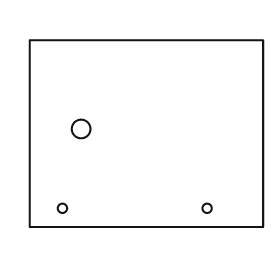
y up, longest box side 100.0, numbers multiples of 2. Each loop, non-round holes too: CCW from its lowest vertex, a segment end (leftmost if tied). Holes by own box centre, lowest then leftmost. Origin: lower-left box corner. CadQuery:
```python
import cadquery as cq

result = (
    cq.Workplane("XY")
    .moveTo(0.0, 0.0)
    .lineTo(100.0, 0.0)
    .lineTo(100.0, 80.0)
    .lineTo(0.0, 80.0)
    .close()
    .moveTo(14.0, 8.0)
    .circle(2.0)
    .moveTo(76.0, 8.0)
    .circle(2.0)
    .moveTo(22.0, 42.0)
    .circle(4.0)
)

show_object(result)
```